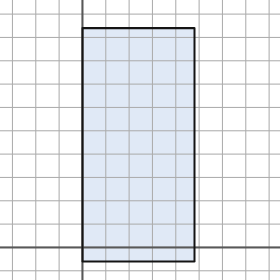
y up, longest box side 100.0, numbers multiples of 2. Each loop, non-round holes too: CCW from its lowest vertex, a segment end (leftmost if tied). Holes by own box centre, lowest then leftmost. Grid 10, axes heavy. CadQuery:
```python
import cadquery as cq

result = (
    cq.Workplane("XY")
    .moveTo(0.0, -6.0)
    .lineTo(48.0, -6.0)
    .lineTo(48.0, 94.0)
    .lineTo(0.0, 94.0)
    .close()
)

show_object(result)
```